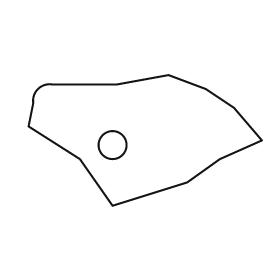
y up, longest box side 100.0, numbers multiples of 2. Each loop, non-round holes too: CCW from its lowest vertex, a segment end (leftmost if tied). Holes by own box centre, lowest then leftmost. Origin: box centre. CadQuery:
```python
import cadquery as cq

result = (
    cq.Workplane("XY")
    .moveTo(-14.0, -28.0)
    .lineTo(18.0, -18.0)
    .lineTo(32.0, -8.0)
    .lineTo(50.0, 0.0)
    .lineTo(38.0, 14.0)
    .lineTo(26.0, 22.0)
    .lineTo(10.0, 28.0)
    .lineTo(-12.0, 24.0)
    .lineTo(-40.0, 24.0)
    .threePointArc((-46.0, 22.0), (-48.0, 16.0))
    .lineTo(-50.0, 6.0)
    .lineTo(-28.0, -8.0)
    .close()
    .moveTo(-14.0, -2.0)
    .circle(6.0)
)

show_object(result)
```